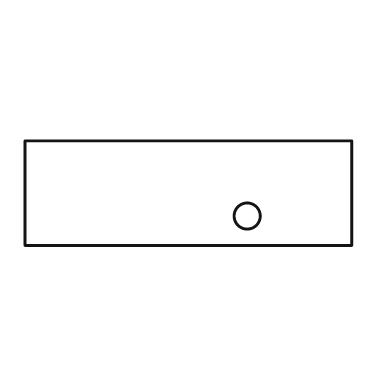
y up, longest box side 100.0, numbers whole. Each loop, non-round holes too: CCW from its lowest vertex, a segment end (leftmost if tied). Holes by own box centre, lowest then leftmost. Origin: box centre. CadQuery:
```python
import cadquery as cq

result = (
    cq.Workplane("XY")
    .moveTo(-50.0, -16.0)
    .lineTo(50.0, -16.0)
    .lineTo(50.0, 16.0)
    .lineTo(-50.0, 16.0)
    .close()
    .moveTo(18.0, -7.0)
    .circle(4.0)
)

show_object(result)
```